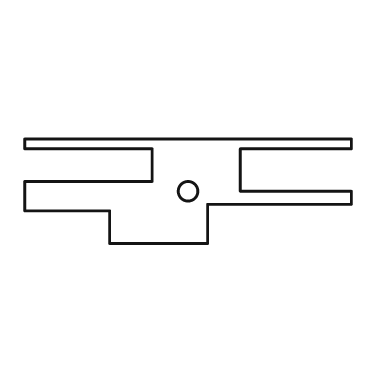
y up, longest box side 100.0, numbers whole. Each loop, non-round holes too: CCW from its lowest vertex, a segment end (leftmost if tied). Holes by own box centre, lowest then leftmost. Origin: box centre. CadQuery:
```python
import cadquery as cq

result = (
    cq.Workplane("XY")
    .moveTo(-24.0, -16.0)
    .lineTo(6.0, -16.0)
    .lineTo(6.0, -4.0)
    .lineTo(50.0, -4.0)
    .lineTo(50.0, 0.0)
    .lineTo(16.0, 0.0)
    .lineTo(16.0, 13.0)
    .lineTo(50.0, 13.0)
    .lineTo(50.0, 16.0)
    .lineTo(-50.0, 16.0)
    .lineTo(-50.0, 13.0)
    .lineTo(-11.0, 13.0)
    .lineTo(-11.0, 3.0)
    .lineTo(-50.0, 3.0)
    .lineTo(-50.0, -6.0)
    .lineTo(-24.0, -6.0)
    .close()
    .moveTo(0.0, 0.0)
    .circle(3.0)
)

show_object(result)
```